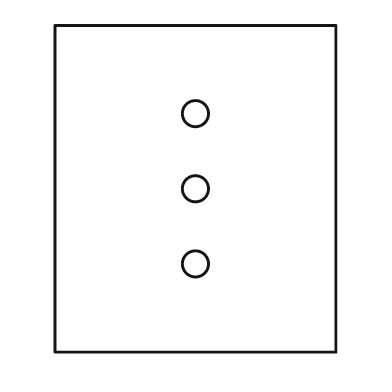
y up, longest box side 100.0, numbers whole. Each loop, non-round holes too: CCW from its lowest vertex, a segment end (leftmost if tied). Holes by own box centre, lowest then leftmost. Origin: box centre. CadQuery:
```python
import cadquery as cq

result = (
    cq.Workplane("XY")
    .moveTo(-43.0, -50.0)
    .lineTo(43.0, -50.0)
    .lineTo(43.0, 50.0)
    .lineTo(-43.0, 50.0)
    .close()
    .moveTo(0.0, -23.0)
    .circle(4.0)
    .moveTo(0.0, 0.0)
    .circle(4.0)
    .moveTo(0.0, 23.0)
    .circle(4.0)
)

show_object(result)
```